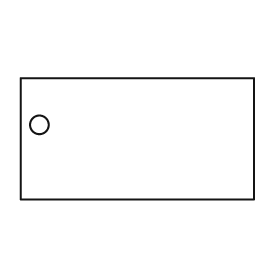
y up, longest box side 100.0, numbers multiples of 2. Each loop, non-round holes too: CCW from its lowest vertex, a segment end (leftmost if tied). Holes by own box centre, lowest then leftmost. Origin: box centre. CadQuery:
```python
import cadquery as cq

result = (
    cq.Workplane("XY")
    .moveTo(-50.0, -26.0)
    .lineTo(50.0, -26.0)
    .lineTo(50.0, 26.0)
    .lineTo(-50.0, 26.0)
    .close()
    .moveTo(-42.0, 6.0)
    .circle(4.0)
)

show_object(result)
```